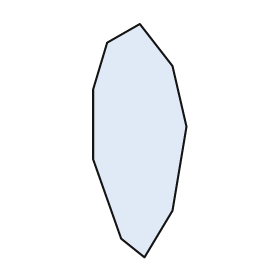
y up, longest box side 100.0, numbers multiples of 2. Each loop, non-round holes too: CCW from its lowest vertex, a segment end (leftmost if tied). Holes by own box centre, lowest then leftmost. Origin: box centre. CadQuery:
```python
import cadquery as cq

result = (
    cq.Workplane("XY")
    .moveTo(2.0, -50.0)
    .lineTo(14.0, -30.0)
    .lineTo(20.0, 6.0)
    .lineTo(14.0, 32.0)
    .lineTo(0.0, 50.0)
    .lineTo(-14.0, 42.0)
    .lineTo(-20.0, 22.0)
    .lineTo(-20.0, -8.0)
    .lineTo(-8.0, -42.0)
    .close()
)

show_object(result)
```